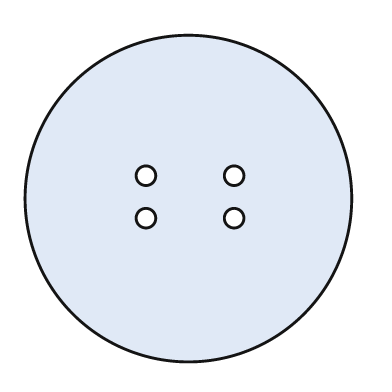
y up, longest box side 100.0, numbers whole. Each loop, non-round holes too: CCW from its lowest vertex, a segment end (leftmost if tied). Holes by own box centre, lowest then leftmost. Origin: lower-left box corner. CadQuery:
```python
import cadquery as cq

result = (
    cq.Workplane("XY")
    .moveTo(50.0, 50.0)
    .circle(50.0)
    .moveTo(37.0, 44.0)
    .circle(3.0)
    .moveTo(64.0, 44.0)
    .circle(3.0)
    .moveTo(37.0, 57.0)
    .circle(3.0)
    .moveTo(64.0, 57.0)
    .circle(3.0)
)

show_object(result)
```